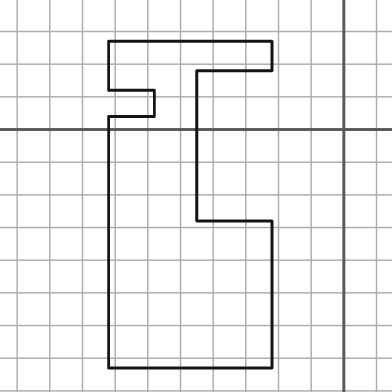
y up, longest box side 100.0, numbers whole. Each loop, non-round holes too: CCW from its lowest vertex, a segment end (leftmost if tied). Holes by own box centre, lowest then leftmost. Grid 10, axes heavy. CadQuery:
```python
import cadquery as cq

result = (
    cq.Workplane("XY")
    .moveTo(-72.0, -73.0)
    .lineTo(-22.0, -73.0)
    .lineTo(-22.0, -28.0)
    .lineTo(-45.0, -28.0)
    .lineTo(-45.0, 18.0)
    .lineTo(-22.0, 18.0)
    .lineTo(-22.0, 27.0)
    .lineTo(-72.0, 27.0)
    .lineTo(-72.0, 12.0)
    .lineTo(-58.0, 12.0)
    .lineTo(-58.0, 4.0)
    .lineTo(-72.0, 4.0)
    .close()
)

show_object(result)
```